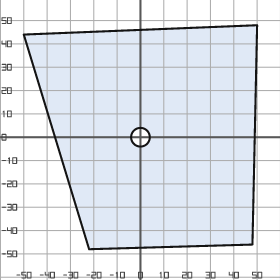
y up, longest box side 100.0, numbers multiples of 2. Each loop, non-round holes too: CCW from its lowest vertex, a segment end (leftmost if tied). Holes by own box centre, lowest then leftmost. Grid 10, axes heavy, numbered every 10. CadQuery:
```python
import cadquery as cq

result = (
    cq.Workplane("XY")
    .moveTo(-22.0, -48.0)
    .lineTo(48.0, -46.0)
    .lineTo(50.0, 48.0)
    .lineTo(-50.0, 44.0)
    .close()
    .moveTo(0.0, 0.0)
    .circle(4.0)
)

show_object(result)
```